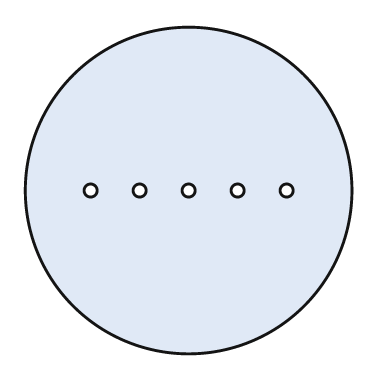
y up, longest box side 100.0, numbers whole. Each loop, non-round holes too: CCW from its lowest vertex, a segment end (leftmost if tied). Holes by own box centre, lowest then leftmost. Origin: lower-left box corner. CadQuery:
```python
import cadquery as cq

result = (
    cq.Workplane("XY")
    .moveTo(50.0, 50.0)
    .circle(50.0)
    .moveTo(20.0, 50.0)
    .circle(2.0)
    .moveTo(35.0, 50.0)
    .circle(2.0)
    .moveTo(50.0, 50.0)
    .circle(2.0)
    .moveTo(65.0, 50.0)
    .circle(2.0)
    .moveTo(80.0, 50.0)
    .circle(2.0)
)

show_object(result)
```